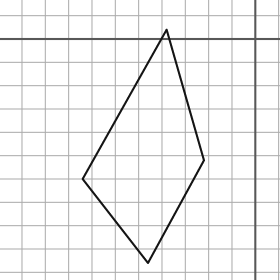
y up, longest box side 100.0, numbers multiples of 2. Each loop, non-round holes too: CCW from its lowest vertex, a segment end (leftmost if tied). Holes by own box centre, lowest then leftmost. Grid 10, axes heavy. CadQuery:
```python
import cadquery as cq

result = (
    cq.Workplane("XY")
    .moveTo(-46.0, -96.0)
    .lineTo(-22.0, -52.0)
    .lineTo(-38.0, 4.0)
    .lineTo(-74.0, -60.0)
    .close()
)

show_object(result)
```